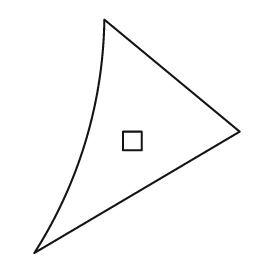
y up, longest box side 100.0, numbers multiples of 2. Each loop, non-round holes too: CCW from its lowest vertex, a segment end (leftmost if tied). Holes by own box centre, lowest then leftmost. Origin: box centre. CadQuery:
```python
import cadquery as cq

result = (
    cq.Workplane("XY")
    .moveTo(-44.0, -50.0)
    .lineTo(44.0, 2.0)
    .lineTo(-14.0, 50.0)
    .threePointArc((-22.0, -2.0), (-44.0, -50.0))
    .close()
    .moveTo(-6.0, -6.0)
    .lineTo(2.0, -6.0)
    .lineTo(2.0, 2.0)
    .lineTo(-6.0, 2.0)
    .close()
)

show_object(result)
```